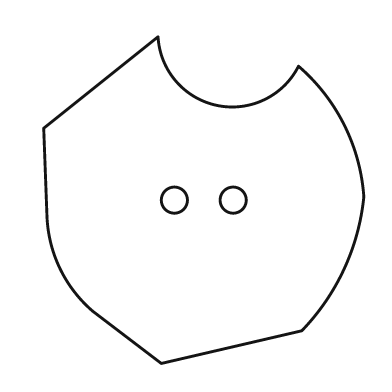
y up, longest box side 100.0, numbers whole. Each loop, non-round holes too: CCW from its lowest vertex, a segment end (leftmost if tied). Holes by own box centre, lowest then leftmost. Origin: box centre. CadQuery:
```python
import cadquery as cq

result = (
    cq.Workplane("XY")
    .moveTo(-13.0, -50.0)
    .lineTo(30.0, -40.0)
    .threePointArc((43.0, -21.0), (49.0, 1.0))
    .threePointArc((43.0, 23.0), (29.0, 41.0))
    .threePointArc((4.0, 29.0), (-14.0, 50.0))
    .lineTo(-49.0, 22.0)
    .lineTo(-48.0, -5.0)
    .threePointArc((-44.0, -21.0), (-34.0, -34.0))
    .close()
    .moveTo(-9.0, 0.0)
    .circle(4.0)
    .moveTo(9.0, 0.0)
    .circle(4.0)
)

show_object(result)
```